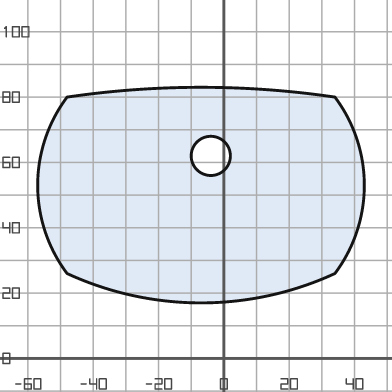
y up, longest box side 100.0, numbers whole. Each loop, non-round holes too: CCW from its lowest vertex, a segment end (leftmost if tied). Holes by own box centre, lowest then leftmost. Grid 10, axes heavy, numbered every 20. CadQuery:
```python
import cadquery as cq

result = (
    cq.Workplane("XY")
    .moveTo(-48.0, 26.0)
    .threePointArc((-7.0, 17.0), (34.0, 26.0))
    .threePointArc((43.0, 53.0), (34.0, 80.0))
    .threePointArc((-7.0, 83.0), (-48.0, 80.0))
    .threePointArc((-57.0, 53.0), (-48.0, 26.0))
    .close()
    .moveTo(-4.0, 62.0)
    .circle(6.0)
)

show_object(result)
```